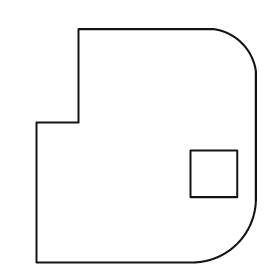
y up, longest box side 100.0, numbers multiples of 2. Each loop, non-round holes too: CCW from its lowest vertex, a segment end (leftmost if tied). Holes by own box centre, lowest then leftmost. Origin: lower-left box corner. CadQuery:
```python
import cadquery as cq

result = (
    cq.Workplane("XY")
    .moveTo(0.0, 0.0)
    .lineTo(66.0, 0.0)
    .threePointArc((86.0, 8.0), (94.0, 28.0))
    .lineTo(94.0, 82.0)
    .threePointArc((88.0, 94.0), (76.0, 100.0))
    .lineTo(18.0, 100.0)
    .lineTo(18.0, 60.0)
    .lineTo(0.0, 60.0)
    .close()
    .moveTo(66.0, 28.0)
    .lineTo(86.0, 28.0)
    .lineTo(86.0, 48.0)
    .lineTo(66.0, 48.0)
    .close()
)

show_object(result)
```